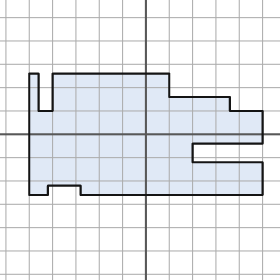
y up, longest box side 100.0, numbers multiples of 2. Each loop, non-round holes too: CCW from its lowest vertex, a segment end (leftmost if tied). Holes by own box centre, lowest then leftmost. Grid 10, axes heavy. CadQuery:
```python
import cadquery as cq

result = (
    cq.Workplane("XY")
    .moveTo(-50.0, -26.0)
    .lineTo(-42.0, -26.0)
    .lineTo(-42.0, -22.0)
    .lineTo(-28.0, -22.0)
    .lineTo(-28.0, -26.0)
    .lineTo(50.0, -26.0)
    .lineTo(50.0, -12.0)
    .lineTo(20.0, -12.0)
    .lineTo(20.0, -4.0)
    .lineTo(50.0, -4.0)
    .lineTo(50.0, 10.0)
    .lineTo(36.0, 10.0)
    .lineTo(36.0, 16.0)
    .lineTo(10.0, 16.0)
    .lineTo(10.0, 26.0)
    .lineTo(-40.0, 26.0)
    .lineTo(-40.0, 10.0)
    .lineTo(-46.0, 10.0)
    .lineTo(-46.0, 26.0)
    .lineTo(-50.0, 26.0)
    .close()
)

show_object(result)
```